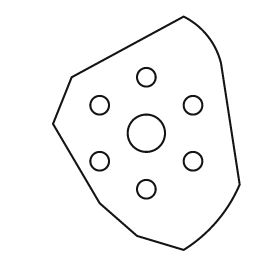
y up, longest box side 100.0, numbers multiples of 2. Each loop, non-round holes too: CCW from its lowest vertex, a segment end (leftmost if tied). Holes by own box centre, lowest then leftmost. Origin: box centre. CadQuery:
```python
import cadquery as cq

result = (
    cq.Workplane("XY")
    .moveTo(16.0, -50.0)
    .threePointArc((30.0, -38.0), (40.0, -22.0))
    .lineTo(32.0, 30.0)
    .threePointArc((26.0, 42.0), (16.0, 50.0))
    .lineTo(-32.0, 24.0)
    .lineTo(-40.0, 4.0)
    .lineTo(-20.0, -30.0)
    .lineTo(-4.0, -44.0)
    .close()
    .moveTo(0.0, -24.0)
    .circle(4.0)
    .moveTo(-20.0, -12.0)
    .circle(4.0)
    .moveTo(20.0, -12.0)
    .circle(4.0)
    .moveTo(0.0, 0.0)
    .circle(8.0)
    .moveTo(-20.0, 12.0)
    .circle(4.0)
    .moveTo(20.0, 12.0)
    .circle(4.0)
    .moveTo(0.0, 24.0)
    .circle(4.0)
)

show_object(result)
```